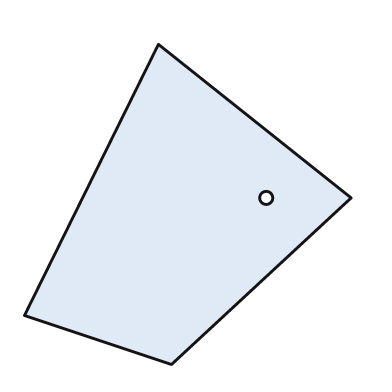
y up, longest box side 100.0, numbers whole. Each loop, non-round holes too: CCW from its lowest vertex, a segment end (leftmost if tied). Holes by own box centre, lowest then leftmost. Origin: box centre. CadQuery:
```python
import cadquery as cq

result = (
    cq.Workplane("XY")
    .moveTo(-5.0, -49.0)
    .lineTo(50.0, 2.0)
    .lineTo(-9.0, 49.0)
    .lineTo(-50.0, -34.0)
    .close()
    .moveTo(24.0, 2.0)
    .circle(2.0)
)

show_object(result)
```